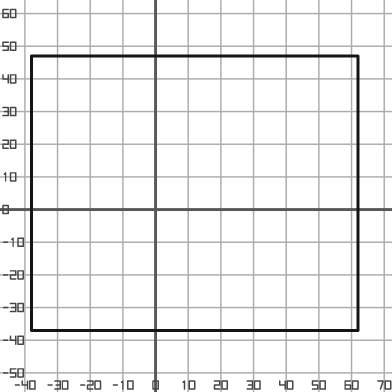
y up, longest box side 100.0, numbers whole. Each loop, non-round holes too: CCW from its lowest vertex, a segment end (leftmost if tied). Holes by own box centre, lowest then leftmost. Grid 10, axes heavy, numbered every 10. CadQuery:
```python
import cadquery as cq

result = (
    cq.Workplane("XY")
    .moveTo(-38.0, -37.0)
    .lineTo(62.0, -37.0)
    .lineTo(62.0, 47.0)
    .lineTo(-38.0, 47.0)
    .close()
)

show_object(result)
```